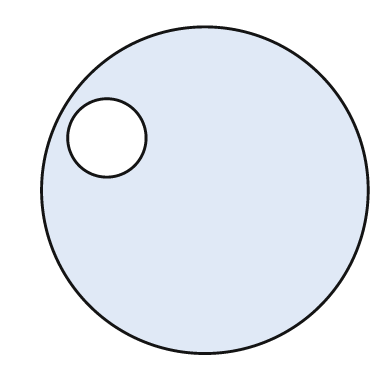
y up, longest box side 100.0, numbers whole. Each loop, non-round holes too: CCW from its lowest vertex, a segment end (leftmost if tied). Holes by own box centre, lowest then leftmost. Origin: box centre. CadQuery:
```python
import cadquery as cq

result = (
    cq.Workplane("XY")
    .moveTo(0.0, 0.0)
    .circle(50.0)
    .moveTo(-30.0, 16.0)
    .circle(12.0)
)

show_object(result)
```